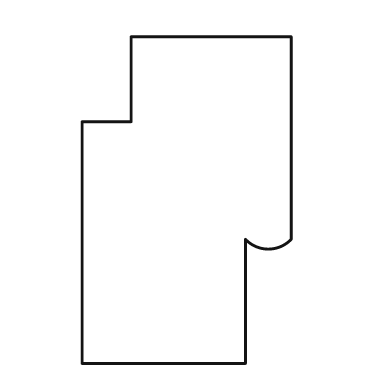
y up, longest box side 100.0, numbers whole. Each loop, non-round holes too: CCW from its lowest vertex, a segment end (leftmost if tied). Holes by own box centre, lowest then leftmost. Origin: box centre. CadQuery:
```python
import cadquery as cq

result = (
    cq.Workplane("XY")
    .moveTo(-32.0, -50.0)
    .lineTo(18.0, -50.0)
    .lineTo(18.0, -12.0)
    .threePointArc((25.0, -15.0), (32.0, -12.0))
    .lineTo(32.0, 50.0)
    .lineTo(-17.0, 50.0)
    .lineTo(-17.0, 24.0)
    .lineTo(-32.0, 24.0)
    .close()
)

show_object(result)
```